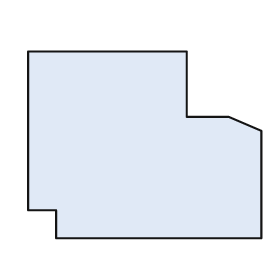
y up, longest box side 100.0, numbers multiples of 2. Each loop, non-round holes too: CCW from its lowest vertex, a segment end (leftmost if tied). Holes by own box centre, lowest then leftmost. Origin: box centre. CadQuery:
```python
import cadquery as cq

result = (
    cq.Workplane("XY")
    .moveTo(-38.0, -40.0)
    .lineTo(50.0, -40.0)
    .lineTo(50.0, 6.0)
    .lineTo(36.0, 12.0)
    .lineTo(18.0, 12.0)
    .lineTo(18.0, 40.0)
    .lineTo(-50.0, 40.0)
    .lineTo(-50.0, -28.0)
    .lineTo(-38.0, -28.0)
    .close()
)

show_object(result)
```